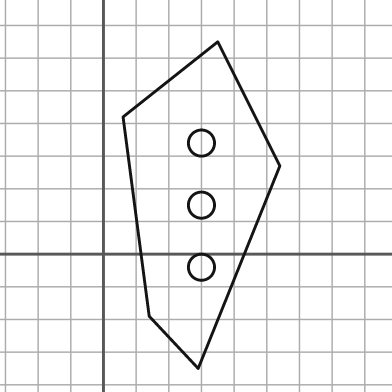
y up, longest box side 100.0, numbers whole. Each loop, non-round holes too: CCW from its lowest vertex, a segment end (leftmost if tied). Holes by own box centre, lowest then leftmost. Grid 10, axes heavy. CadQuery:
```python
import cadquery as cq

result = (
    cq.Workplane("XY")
    .moveTo(29.0, -35.0)
    .lineTo(54.0, 27.0)
    .lineTo(35.0, 65.0)
    .lineTo(6.0, 42.0)
    .lineTo(14.0, -19.0)
    .close()
    .moveTo(30.0, -4.0)
    .circle(4.0)
    .moveTo(30.0, 15.0)
    .circle(4.0)
    .moveTo(30.0, 34.0)
    .circle(4.0)
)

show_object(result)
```